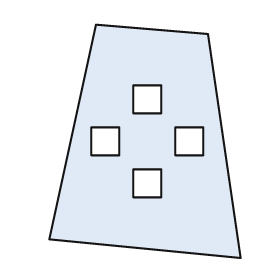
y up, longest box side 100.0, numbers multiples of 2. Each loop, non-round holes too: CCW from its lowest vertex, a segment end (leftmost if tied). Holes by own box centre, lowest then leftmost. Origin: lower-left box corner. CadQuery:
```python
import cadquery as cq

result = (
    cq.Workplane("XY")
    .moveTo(82.0, 0.0)
    .lineTo(68.0, 96.0)
    .lineTo(20.0, 100.0)
    .lineTo(0.0, 8.0)
    .close()
    .moveTo(36.0, 26.0)
    .lineTo(48.0, 26.0)
    .lineTo(48.0, 38.0)
    .lineTo(36.0, 38.0)
    .close()
    .moveTo(18.0, 44.0)
    .lineTo(30.0, 44.0)
    .lineTo(30.0, 56.0)
    .lineTo(18.0, 56.0)
    .close()
    .moveTo(54.0, 44.0)
    .lineTo(66.0, 44.0)
    .lineTo(66.0, 56.0)
    .lineTo(54.0, 56.0)
    .close()
    .moveTo(36.0, 62.0)
    .lineTo(48.0, 62.0)
    .lineTo(48.0, 74.0)
    .lineTo(36.0, 74.0)
    .close()
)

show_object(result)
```